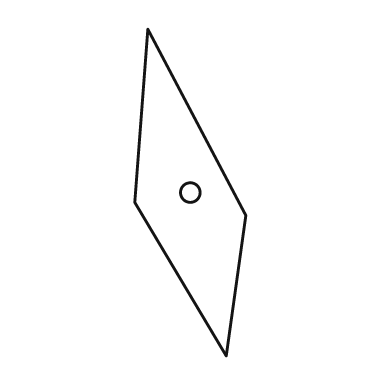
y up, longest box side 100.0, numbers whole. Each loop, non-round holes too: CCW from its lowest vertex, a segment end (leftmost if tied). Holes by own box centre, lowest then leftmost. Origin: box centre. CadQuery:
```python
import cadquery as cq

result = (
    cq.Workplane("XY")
    .moveTo(11.0, -50.0)
    .lineTo(17.0, -7.0)
    .lineTo(-13.0, 50.0)
    .lineTo(-17.0, -3.0)
    .close()
    .moveTo(0.0, 0.0)
    .circle(3.0)
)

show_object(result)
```